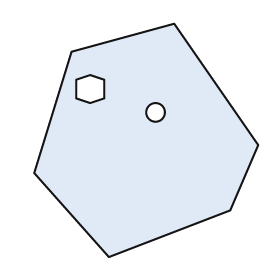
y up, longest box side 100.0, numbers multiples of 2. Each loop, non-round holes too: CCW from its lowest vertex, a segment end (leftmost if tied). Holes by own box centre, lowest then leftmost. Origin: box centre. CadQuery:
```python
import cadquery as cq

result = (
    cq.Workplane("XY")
    .moveTo(-16.0, -50.0)
    .lineTo(36.0, -30.0)
    .lineTo(48.0, -2.0)
    .lineTo(12.0, 50.0)
    .lineTo(-32.0, 38.0)
    .lineTo(-48.0, -14.0)
    .close()
    .moveTo(4.0, 12.0)
    .circle(4.0)
    .moveTo(-24.0, 16.0)
    .lineTo(-18.0, 18.0)
    .lineTo(-18.0, 26.0)
    .lineTo(-24.0, 28.0)
    .lineTo(-30.0, 26.0)
    .lineTo(-30.0, 18.0)
    .close()
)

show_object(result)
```